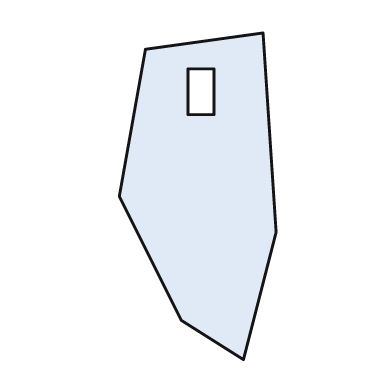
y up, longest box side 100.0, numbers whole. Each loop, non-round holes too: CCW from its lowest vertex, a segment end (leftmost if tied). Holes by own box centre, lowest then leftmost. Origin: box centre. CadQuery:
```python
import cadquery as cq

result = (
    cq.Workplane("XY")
    .moveTo(14.0, -50.0)
    .lineTo(24.0, -11.0)
    .lineTo(20.0, 50.0)
    .lineTo(-16.0, 45.0)
    .lineTo(-24.0, 0.0)
    .lineTo(-5.0, -38.0)
    .close()
    .moveTo(-3.0, 25.0)
    .lineTo(5.0, 25.0)
    .lineTo(5.0, 39.0)
    .lineTo(-3.0, 39.0)
    .close()
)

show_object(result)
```